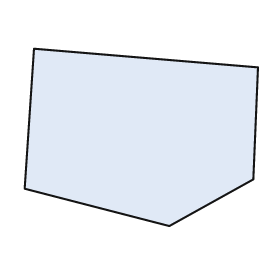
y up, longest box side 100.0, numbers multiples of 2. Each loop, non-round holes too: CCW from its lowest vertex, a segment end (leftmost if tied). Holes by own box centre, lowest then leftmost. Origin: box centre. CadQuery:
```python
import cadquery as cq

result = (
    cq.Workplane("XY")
    .moveTo(12.0, -38.0)
    .lineTo(48.0, -18.0)
    .lineTo(50.0, 30.0)
    .lineTo(-46.0, 38.0)
    .lineTo(-50.0, -22.0)
    .close()
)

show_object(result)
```